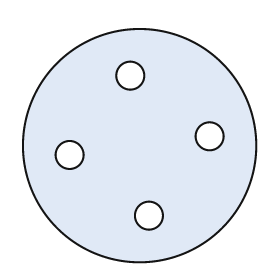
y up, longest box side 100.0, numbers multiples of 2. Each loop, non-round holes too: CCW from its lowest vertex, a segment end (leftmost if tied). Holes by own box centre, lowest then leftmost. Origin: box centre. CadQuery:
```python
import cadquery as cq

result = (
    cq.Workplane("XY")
    .moveTo(0.0, 0.0)
    .circle(50.0)
    .moveTo(4.0, -30.0)
    .circle(6.0)
    .moveTo(-30.0, -4.0)
    .circle(6.0)
    .moveTo(30.0, 4.0)
    .circle(6.0)
    .moveTo(-4.0, 30.0)
    .circle(6.0)
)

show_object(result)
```